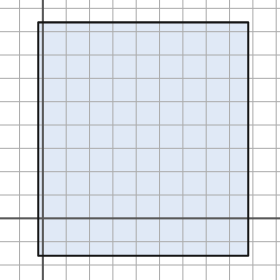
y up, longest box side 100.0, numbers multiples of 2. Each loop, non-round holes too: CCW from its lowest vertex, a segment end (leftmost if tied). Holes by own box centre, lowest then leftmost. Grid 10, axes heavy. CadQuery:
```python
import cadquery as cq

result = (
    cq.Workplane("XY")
    .moveTo(-2.0, -16.0)
    .lineTo(88.0, -16.0)
    .lineTo(88.0, 84.0)
    .lineTo(-2.0, 84.0)
    .close()
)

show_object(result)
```